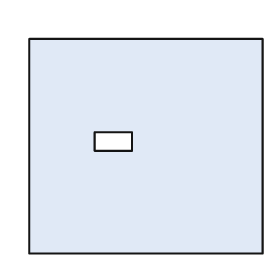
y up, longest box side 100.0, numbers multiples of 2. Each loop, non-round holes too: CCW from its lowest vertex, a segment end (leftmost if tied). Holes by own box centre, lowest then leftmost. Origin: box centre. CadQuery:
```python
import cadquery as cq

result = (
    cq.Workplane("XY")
    .moveTo(-50.0, -46.0)
    .lineTo(50.0, -46.0)
    .lineTo(50.0, 46.0)
    .lineTo(-50.0, 46.0)
    .close()
    .moveTo(-22.0, -2.0)
    .lineTo(-6.0, -2.0)
    .lineTo(-6.0, 6.0)
    .lineTo(-22.0, 6.0)
    .close()
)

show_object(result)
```